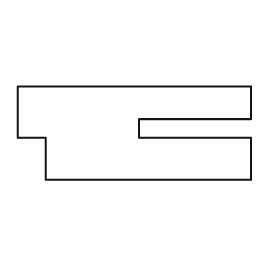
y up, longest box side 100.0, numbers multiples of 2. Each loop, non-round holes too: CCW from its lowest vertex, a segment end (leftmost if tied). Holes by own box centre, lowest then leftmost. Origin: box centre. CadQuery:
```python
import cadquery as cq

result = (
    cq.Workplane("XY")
    .moveTo(-38.0, -20.0)
    .lineTo(50.0, -20.0)
    .lineTo(50.0, -2.0)
    .lineTo(2.0, -2.0)
    .lineTo(2.0, 6.0)
    .lineTo(50.0, 6.0)
    .lineTo(50.0, 20.0)
    .lineTo(-50.0, 20.0)
    .lineTo(-50.0, -2.0)
    .lineTo(-38.0, -2.0)
    .close()
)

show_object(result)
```